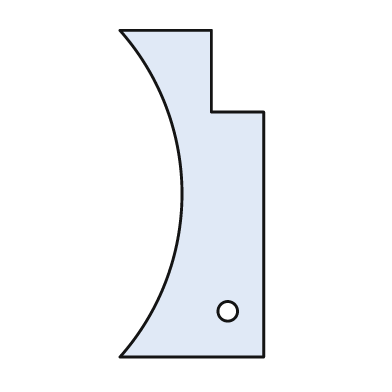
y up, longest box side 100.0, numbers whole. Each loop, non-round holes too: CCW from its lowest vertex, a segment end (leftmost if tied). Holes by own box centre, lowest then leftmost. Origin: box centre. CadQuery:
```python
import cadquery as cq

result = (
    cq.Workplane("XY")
    .moveTo(-22.0, -50.0)
    .lineTo(22.0, -50.0)
    .lineTo(22.0, 25.0)
    .lineTo(6.0, 25.0)
    .lineTo(6.0, 50.0)
    .lineTo(-22.0, 50.0)
    .threePointArc((-3.0, 0.0), (-22.0, -50.0))
    .close()
    .moveTo(11.0, -36.0)
    .circle(3.0)
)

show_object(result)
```